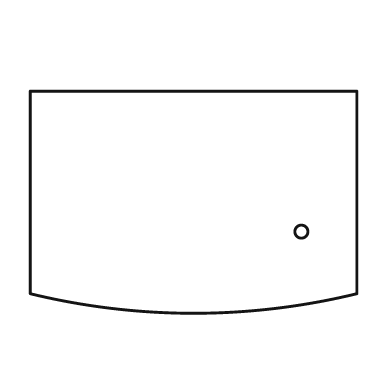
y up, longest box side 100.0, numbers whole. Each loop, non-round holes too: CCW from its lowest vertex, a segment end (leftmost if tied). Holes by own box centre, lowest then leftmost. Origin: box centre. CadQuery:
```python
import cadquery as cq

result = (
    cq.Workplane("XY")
    .moveTo(-50.0, -28.0)
    .threePointArc((0.0, -34.0), (50.0, -28.0))
    .lineTo(50.0, 34.0)
    .lineTo(-50.0, 34.0)
    .close()
    .moveTo(33.0, -9.0)
    .circle(2.0)
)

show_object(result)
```